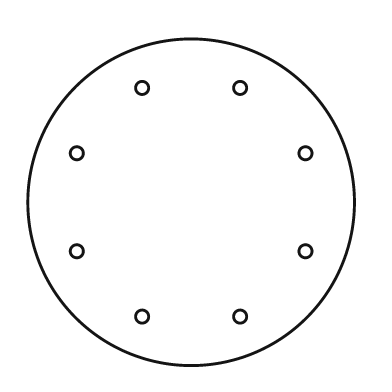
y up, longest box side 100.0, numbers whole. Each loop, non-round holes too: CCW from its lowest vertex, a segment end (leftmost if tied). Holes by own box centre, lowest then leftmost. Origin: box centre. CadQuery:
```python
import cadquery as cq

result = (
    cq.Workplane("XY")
    .moveTo(0.0, 0.0)
    .circle(50.0)
    .moveTo(-15.0, -35.0)
    .circle(2.0)
    .moveTo(15.0, -35.0)
    .circle(2.0)
    .moveTo(-35.0, -15.0)
    .circle(2.0)
    .moveTo(35.0, -15.0)
    .circle(2.0)
    .moveTo(-35.0, 15.0)
    .circle(2.0)
    .moveTo(35.0, 15.0)
    .circle(2.0)
    .moveTo(-15.0, 35.0)
    .circle(2.0)
    .moveTo(15.0, 35.0)
    .circle(2.0)
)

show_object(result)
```